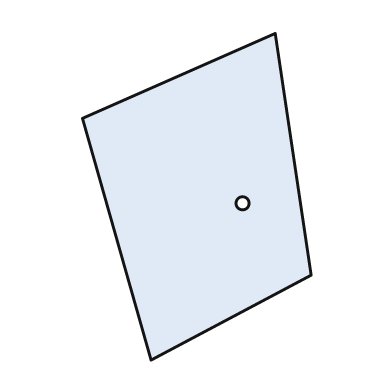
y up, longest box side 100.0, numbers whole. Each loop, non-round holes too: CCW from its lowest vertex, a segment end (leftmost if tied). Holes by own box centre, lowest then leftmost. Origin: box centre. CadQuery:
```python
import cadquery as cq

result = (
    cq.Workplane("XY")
    .moveTo(-14.0, -50.0)
    .lineTo(35.0, -24.0)
    .lineTo(24.0, 50.0)
    .lineTo(-35.0, 24.0)
    .close()
    .moveTo(14.0, -2.0)
    .circle(2.0)
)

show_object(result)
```